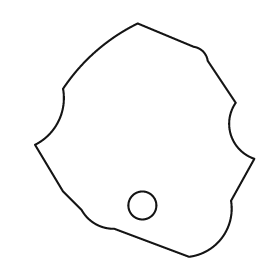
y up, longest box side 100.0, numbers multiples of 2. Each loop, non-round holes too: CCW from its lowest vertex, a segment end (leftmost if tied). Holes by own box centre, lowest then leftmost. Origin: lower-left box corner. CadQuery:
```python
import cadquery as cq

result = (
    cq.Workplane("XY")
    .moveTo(66.0, 0.0)
    .threePointArc((80.0, 8.0), (84.0, 24.0))
    .lineTo(94.0, 42.0)
    .threePointArc((84.0, 52.0), (86.0, 66.0))
    .lineTo(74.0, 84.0)
    .threePointArc((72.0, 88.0), (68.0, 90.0))
    .lineTo(44.0, 100.0)
    .threePointArc((26.0, 88.0), (12.0, 72.0))
    .threePointArc((10.0, 58.0), (0.0, 48.0))
    .lineTo(12.0, 28.0)
    .lineTo(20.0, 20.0)
    .threePointArc((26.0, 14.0), (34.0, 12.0))
    .close()
    .moveTo(46.0, 22.0)
    .circle(6.0)
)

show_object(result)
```